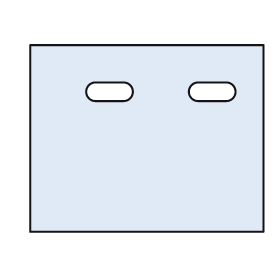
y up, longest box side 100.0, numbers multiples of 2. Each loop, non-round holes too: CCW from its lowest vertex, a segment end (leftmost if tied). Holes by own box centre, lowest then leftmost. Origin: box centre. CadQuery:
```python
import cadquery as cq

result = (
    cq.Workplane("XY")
    .moveTo(-50.0, -40.0)
    .lineTo(50.0, -40.0)
    .lineTo(50.0, 40.0)
    .lineTo(-50.0, 40.0)
    .close()
    .moveTo(-22.0, 16.0)
    .lineTo(-10.0, 16.0)
    .threePointArc((-6.0, 20.0), (-10.0, 24.0))
    .lineTo(-22.0, 24.0)
    .threePointArc((-26.0, 20.0), (-22.0, 16.0))
    .close()
    .moveTo(22.0, 16.0)
    .lineTo(34.0, 16.0)
    .threePointArc((38.0, 20.0), (34.0, 24.0))
    .lineTo(22.0, 24.0)
    .threePointArc((18.0, 20.0), (22.0, 16.0))
    .close()
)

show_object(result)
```